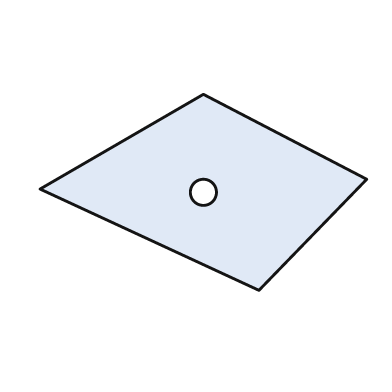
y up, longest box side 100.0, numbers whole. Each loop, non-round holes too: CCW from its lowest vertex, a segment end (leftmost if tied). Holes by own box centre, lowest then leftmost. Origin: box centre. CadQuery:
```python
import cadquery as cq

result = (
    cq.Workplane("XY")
    .moveTo(17.0, -30.0)
    .lineTo(50.0, 4.0)
    .lineTo(0.0, 30.0)
    .lineTo(-50.0, 1.0)
    .close()
    .moveTo(0.0, 0.0)
    .circle(4.0)
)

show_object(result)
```